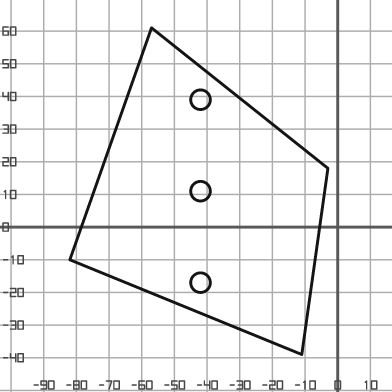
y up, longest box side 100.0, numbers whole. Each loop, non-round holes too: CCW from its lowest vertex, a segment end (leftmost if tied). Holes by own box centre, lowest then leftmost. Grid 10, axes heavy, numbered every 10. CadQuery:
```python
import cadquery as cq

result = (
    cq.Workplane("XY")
    .moveTo(-11.0, -39.0)
    .lineTo(-3.0, 18.0)
    .lineTo(-57.0, 61.0)
    .lineTo(-82.0, -10.0)
    .close()
    .moveTo(-42.0, -17.0)
    .circle(3.0)
    .moveTo(-42.0, 11.0)
    .circle(3.0)
    .moveTo(-42.0, 39.0)
    .circle(3.0)
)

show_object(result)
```